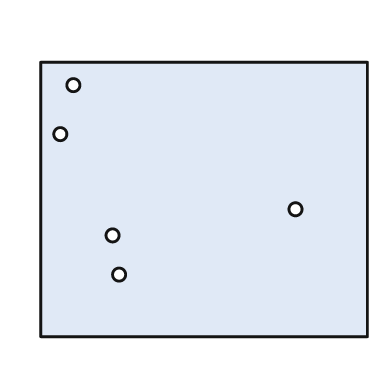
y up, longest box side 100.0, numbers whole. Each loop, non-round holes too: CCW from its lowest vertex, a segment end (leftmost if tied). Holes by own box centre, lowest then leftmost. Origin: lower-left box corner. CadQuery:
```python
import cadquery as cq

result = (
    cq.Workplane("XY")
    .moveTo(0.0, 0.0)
    .lineTo(100.0, 0.0)
    .lineTo(100.0, 84.0)
    .lineTo(0.0, 84.0)
    .close()
    .moveTo(24.0, 19.0)
    .circle(2.0)
    .moveTo(22.0, 31.0)
    .circle(2.0)
    .moveTo(78.0, 39.0)
    .circle(2.0)
    .moveTo(6.0, 62.0)
    .circle(2.0)
    .moveTo(10.0, 77.0)
    .circle(2.0)
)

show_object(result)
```